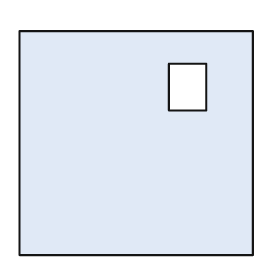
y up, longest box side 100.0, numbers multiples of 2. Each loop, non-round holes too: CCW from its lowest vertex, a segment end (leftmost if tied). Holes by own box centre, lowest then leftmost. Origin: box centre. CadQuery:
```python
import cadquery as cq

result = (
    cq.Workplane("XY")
    .moveTo(-50.0, -48.0)
    .lineTo(50.0, -48.0)
    .lineTo(50.0, 48.0)
    .lineTo(-50.0, 48.0)
    .close()
    .moveTo(14.0, 14.0)
    .lineTo(30.0, 14.0)
    .lineTo(30.0, 34.0)
    .lineTo(14.0, 34.0)
    .close()
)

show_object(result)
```